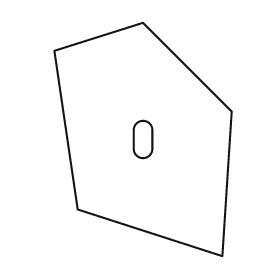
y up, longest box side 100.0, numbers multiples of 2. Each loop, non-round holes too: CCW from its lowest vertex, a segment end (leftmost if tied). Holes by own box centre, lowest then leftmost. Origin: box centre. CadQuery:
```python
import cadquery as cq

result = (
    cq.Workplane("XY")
    .moveTo(34.0, -50.0)
    .lineTo(38.0, 12.0)
    .lineTo(0.0, 50.0)
    .lineTo(-38.0, 38.0)
    .lineTo(-28.0, -30.0)
    .close()
    .moveTo(-4.0, -4.0)
    .threePointArc((0.0, -8.0), (4.0, -4.0))
    .lineTo(4.0, 4.0)
    .threePointArc((0.0, 8.0), (-4.0, 4.0))
    .close()
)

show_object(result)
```